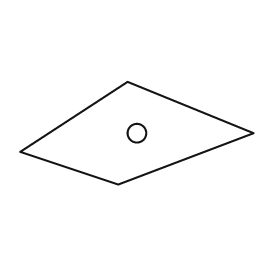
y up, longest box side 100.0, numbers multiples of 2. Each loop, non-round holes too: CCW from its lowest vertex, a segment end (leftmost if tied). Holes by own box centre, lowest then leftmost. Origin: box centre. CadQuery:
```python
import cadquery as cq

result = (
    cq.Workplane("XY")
    .moveTo(-8.0, -22.0)
    .lineTo(50.0, 0.0)
    .lineTo(-4.0, 22.0)
    .lineTo(-50.0, -8.0)
    .close()
    .moveTo(0.0, 0.0)
    .circle(4.0)
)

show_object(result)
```